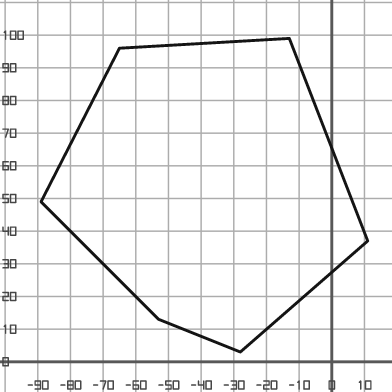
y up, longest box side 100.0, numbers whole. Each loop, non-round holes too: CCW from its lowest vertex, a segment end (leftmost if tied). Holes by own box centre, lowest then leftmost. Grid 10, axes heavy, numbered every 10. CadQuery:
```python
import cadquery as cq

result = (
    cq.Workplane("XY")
    .moveTo(-28.0, 3.0)
    .lineTo(11.0, 37.0)
    .lineTo(-13.0, 99.0)
    .lineTo(-65.0, 96.0)
    .lineTo(-89.0, 49.0)
    .lineTo(-53.0, 13.0)
    .close()
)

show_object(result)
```